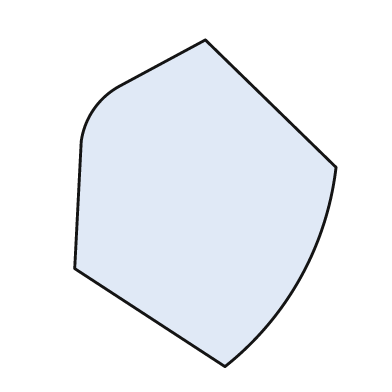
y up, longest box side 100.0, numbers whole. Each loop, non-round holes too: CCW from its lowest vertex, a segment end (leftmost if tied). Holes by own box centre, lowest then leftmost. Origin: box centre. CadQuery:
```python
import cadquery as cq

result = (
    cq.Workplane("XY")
    .moveTo(6.0, -50.0)
    .threePointArc((29.0, -23.0), (40.0, 11.0))
    .lineTo(0.0, 50.0)
    .lineTo(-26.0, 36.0)
    .threePointArc((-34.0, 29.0), (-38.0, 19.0))
    .lineTo(-40.0, -20.0)
    .close()
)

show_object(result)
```